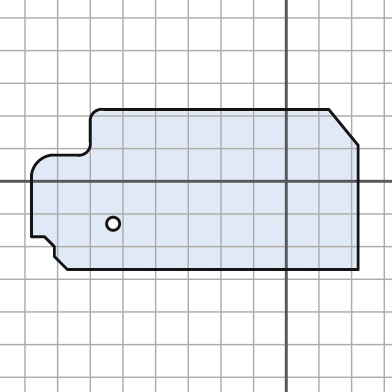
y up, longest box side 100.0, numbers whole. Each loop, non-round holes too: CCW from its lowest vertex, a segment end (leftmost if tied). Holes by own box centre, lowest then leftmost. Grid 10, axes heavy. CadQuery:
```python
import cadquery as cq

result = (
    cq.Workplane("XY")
    .moveTo(-67.0, -27.0)
    .lineTo(22.0, -27.0)
    .lineTo(22.0, 11.0)
    .lineTo(13.0, 22.0)
    .lineTo(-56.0, 22.0)
    .threePointArc((-59.0, 21.0), (-60.0, 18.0))
    .lineTo(-60.0, 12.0)
    .threePointArc((-61.0, 9.0), (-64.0, 8.0))
    .lineTo(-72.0, 8.0)
    .threePointArc((-76.0, 6.0), (-78.0, 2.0))
    .lineTo(-78.0, -17.0)
    .lineTo(-74.0, -17.0)
    .lineTo(-71.0, -20.0)
    .lineTo(-71.0, -23.0)
    .close()
    .moveTo(-53.0, -13.0)
    .circle(2.0)
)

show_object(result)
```